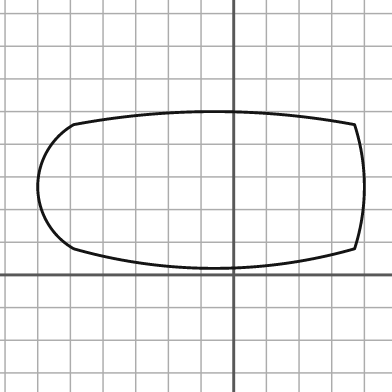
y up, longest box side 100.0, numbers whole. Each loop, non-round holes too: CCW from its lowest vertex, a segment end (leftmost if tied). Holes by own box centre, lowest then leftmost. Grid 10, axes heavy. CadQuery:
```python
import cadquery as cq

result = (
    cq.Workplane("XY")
    .moveTo(-49.0, 8.0)
    .threePointArc((-6.0, 2.0), (37.0, 8.0))
    .threePointArc((40.0, 27.0), (37.0, 46.0))
    .threePointArc((-6.0, 50.0), (-49.0, 46.0))
    .threePointArc((-60.0, 27.0), (-49.0, 8.0))
    .close()
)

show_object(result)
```